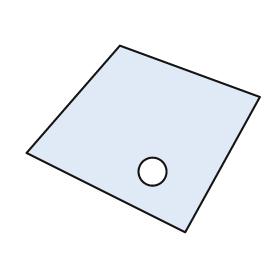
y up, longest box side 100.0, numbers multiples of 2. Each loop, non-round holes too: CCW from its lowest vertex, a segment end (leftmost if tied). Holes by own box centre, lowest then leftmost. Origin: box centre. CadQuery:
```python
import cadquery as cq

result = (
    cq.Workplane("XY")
    .moveTo(18.0, -40.0)
    .lineTo(50.0, 18.0)
    .lineTo(-10.0, 40.0)
    .lineTo(-50.0, -6.0)
    .close()
    .moveTo(4.0, -14.0)
    .circle(6.0)
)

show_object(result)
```